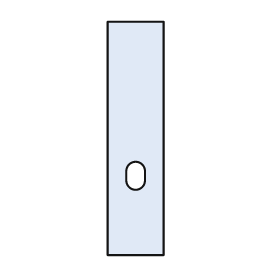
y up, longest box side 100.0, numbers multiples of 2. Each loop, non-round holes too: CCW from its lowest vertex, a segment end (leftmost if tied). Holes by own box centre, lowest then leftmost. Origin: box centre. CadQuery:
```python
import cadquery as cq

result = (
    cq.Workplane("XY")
    .moveTo(-12.0, -50.0)
    .lineTo(12.0, -50.0)
    .lineTo(12.0, 50.0)
    .lineTo(-12.0, 50.0)
    .close()
    .moveTo(-4.0, -18.0)
    .threePointArc((0.0, -22.0), (4.0, -18.0))
    .lineTo(4.0, -14.0)
    .threePointArc((0.0, -10.0), (-4.0, -14.0))
    .close()
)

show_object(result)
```